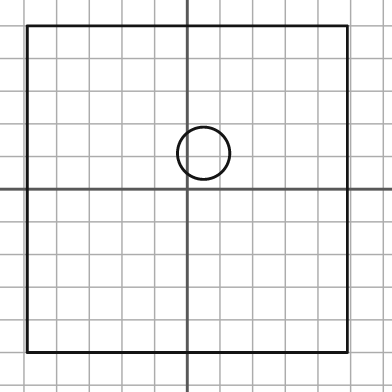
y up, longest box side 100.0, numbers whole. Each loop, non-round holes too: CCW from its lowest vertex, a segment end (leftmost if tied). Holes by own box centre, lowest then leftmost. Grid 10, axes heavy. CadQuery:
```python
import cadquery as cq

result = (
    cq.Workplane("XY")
    .moveTo(-49.0, -50.0)
    .lineTo(49.0, -50.0)
    .lineTo(49.0, 50.0)
    .lineTo(-49.0, 50.0)
    .close()
    .moveTo(5.0, 11.0)
    .circle(8.0)
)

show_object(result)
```